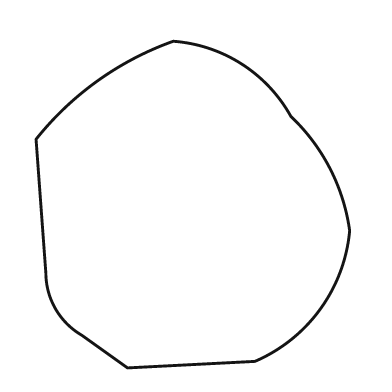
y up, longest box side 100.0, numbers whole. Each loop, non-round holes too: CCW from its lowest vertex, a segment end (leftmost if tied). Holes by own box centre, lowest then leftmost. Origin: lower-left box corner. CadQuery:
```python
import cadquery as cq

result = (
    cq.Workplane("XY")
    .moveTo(28.0, 0.0)
    .lineTo(67.0, 2.0)
    .threePointArc((87.0, 18.0), (96.0, 42.0))
    .threePointArc((90.0, 61.0), (78.0, 77.0))
    .threePointArc((63.0, 93.0), (42.0, 100.0))
    .threePointArc((19.0, 88.0), (0.0, 70.0))
    .lineTo(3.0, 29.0)
    .threePointArc((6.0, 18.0), (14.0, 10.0))
    .close()
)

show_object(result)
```